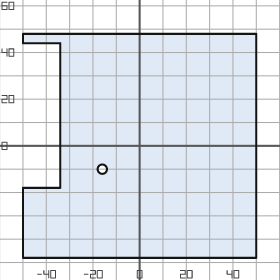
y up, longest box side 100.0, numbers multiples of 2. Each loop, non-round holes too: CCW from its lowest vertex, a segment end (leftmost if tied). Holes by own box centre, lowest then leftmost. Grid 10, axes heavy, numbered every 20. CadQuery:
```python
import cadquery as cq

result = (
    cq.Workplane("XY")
    .moveTo(-50.0, -48.0)
    .lineTo(50.0, -48.0)
    .lineTo(50.0, 48.0)
    .lineTo(-50.0, 48.0)
    .lineTo(-50.0, 44.0)
    .lineTo(-34.0, 44.0)
    .lineTo(-34.0, -18.0)
    .lineTo(-50.0, -18.0)
    .close()
    .moveTo(-16.0, -10.0)
    .circle(2.0)
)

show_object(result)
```